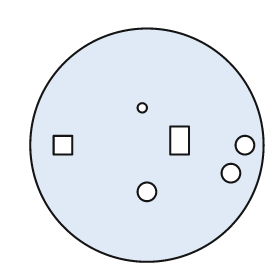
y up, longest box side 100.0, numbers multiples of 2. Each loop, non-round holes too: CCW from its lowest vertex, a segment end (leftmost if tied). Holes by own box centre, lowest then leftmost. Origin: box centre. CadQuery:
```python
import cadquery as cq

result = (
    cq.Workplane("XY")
    .moveTo(0.0, 0.0)
    .circle(50.0)
    .moveTo(0.0, -20.0)
    .circle(4.0)
    .moveTo(36.0, -12.0)
    .circle(4.0)
    .moveTo(-40.0, -4.0)
    .lineTo(-32.0, -4.0)
    .lineTo(-32.0, 4.0)
    .lineTo(-40.0, 4.0)
    .close()
    .moveTo(42.0, 0.0)
    .circle(4.0)
    .moveTo(10.0, -4.0)
    .lineTo(18.0, -4.0)
    .lineTo(18.0, 8.0)
    .lineTo(10.0, 8.0)
    .close()
    .moveTo(-2.0, 16.0)
    .circle(2.0)
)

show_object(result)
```